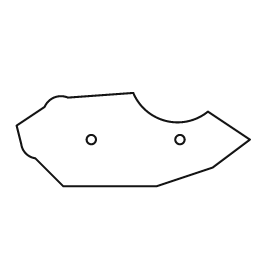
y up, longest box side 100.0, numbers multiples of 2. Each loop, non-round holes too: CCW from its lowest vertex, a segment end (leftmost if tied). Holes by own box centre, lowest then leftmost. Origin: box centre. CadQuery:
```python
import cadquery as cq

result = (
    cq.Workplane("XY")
    .moveTo(-30.0, -20.0)
    .lineTo(10.0, -20.0)
    .lineTo(34.0, -12.0)
    .lineTo(50.0, 0.0)
    .lineTo(32.0, 12.0)
    .threePointArc((14.0, 8.0), (0.0, 20.0))
    .lineTo(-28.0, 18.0)
    .threePointArc((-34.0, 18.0), (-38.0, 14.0))
    .lineTo(-50.0, 6.0)
    .lineTo(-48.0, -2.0)
    .threePointArc((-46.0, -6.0), (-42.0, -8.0))
    .close()
    .moveTo(-18.0, 0.0)
    .circle(2.0)
    .moveTo(20.0, 0.0)
    .circle(2.0)
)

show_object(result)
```